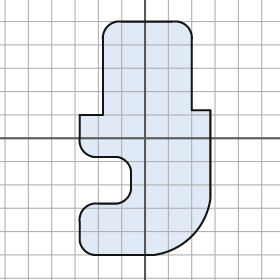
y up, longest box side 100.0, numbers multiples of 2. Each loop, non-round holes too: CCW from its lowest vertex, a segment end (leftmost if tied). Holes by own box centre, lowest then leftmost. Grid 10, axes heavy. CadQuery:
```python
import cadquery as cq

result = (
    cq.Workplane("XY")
    .moveTo(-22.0, -50.0)
    .lineTo(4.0, -50.0)
    .threePointArc((20.0, -42.0), (28.0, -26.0))
    .lineTo(28.0, 12.0)
    .lineTo(20.0, 12.0)
    .lineTo(20.0, 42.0)
    .threePointArc((18.0, 48.0), (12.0, 50.0))
    .lineTo(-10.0, 50.0)
    .threePointArc((-16.0, 48.0), (-18.0, 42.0))
    .lineTo(-18.0, 10.0)
    .lineTo(-28.0, 10.0)
    .lineTo(-28.0, 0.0)
    .threePointArc((-26.0, -6.0), (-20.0, -8.0))
    .lineTo(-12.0, -8.0)
    .threePointArc((-8.0, -10.0), (-6.0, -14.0))
    .lineTo(-6.0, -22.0)
    .threePointArc((-8.0, -26.0), (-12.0, -28.0))
    .lineTo(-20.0, -28.0)
    .threePointArc((-26.0, -30.0), (-28.0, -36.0))
    .lineTo(-28.0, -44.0)
    .threePointArc((-26.0, -48.0), (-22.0, -50.0))
    .close()
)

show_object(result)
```